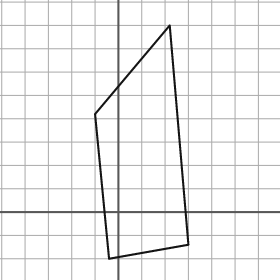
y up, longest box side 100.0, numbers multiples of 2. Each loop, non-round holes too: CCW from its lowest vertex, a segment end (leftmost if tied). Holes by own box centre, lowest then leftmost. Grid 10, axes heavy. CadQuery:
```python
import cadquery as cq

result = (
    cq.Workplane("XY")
    .moveTo(-4.0, -20.0)
    .lineTo(30.0, -14.0)
    .lineTo(22.0, 80.0)
    .lineTo(-10.0, 42.0)
    .close()
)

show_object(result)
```